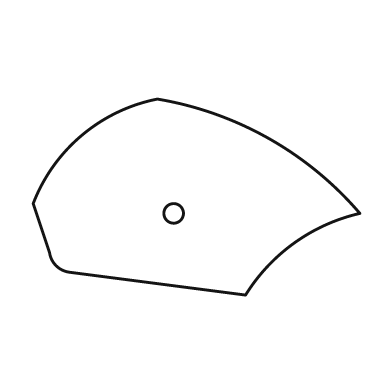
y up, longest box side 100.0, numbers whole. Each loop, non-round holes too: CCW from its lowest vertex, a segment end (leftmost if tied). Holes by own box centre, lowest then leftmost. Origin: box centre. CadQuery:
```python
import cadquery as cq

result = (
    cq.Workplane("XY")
    .moveTo(15.0, -30.0)
    .threePointArc((30.0, -14.0), (50.0, -5.0))
    .threePointArc((22.0, 18.0), (-12.0, 30.0))
    .threePointArc((-35.0, 19.0), (-50.0, -2.0))
    .lineTo(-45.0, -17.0)
    .threePointArc((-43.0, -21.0), (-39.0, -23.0))
    .close()
    .moveTo(-7.0, -5.0)
    .circle(3.0)
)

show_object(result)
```